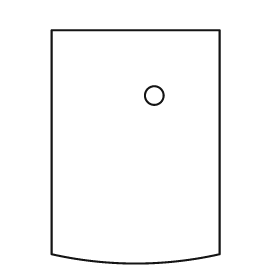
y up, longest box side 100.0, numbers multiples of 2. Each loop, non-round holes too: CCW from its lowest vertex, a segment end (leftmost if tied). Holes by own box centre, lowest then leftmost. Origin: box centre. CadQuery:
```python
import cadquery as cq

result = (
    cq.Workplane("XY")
    .moveTo(-36.0, -46.0)
    .threePointArc((0.0, -50.0), (36.0, -46.0))
    .lineTo(36.0, 50.0)
    .lineTo(-36.0, 50.0)
    .close()
    .moveTo(8.0, 22.0)
    .circle(4.0)
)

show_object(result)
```